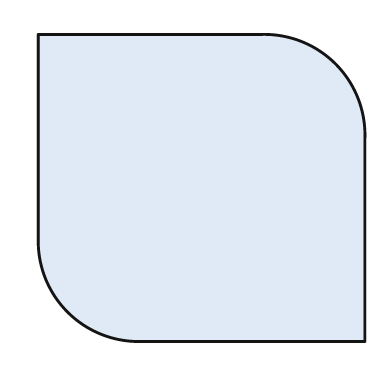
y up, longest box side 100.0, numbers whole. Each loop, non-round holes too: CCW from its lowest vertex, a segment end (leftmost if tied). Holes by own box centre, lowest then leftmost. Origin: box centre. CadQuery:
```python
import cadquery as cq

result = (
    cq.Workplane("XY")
    .moveTo(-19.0, -47.0)
    .lineTo(50.0, -47.0)
    .lineTo(50.0, 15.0)
    .threePointArc((41.0, 38.0), (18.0, 47.0))
    .lineTo(-50.0, 47.0)
    .lineTo(-50.0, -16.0)
    .threePointArc((-41.0, -38.0), (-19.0, -47.0))
    .close()
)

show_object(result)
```